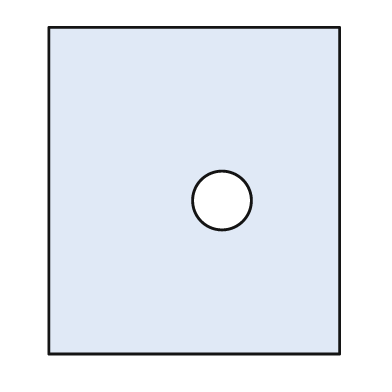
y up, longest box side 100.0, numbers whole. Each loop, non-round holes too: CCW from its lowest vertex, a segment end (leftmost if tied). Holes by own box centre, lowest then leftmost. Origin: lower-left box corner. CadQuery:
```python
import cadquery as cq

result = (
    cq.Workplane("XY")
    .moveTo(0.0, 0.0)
    .lineTo(89.0, 0.0)
    .lineTo(89.0, 100.0)
    .lineTo(0.0, 100.0)
    .close()
    .moveTo(53.0, 47.0)
    .circle(9.0)
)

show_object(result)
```